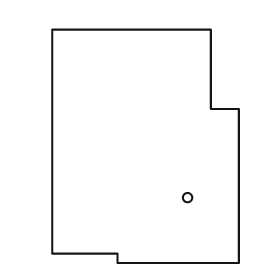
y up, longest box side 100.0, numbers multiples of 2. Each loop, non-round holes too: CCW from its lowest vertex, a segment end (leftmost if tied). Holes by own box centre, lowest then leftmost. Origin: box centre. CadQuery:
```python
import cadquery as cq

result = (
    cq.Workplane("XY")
    .moveTo(-12.0, -50.0)
    .lineTo(40.0, -50.0)
    .lineTo(40.0, 16.0)
    .lineTo(28.0, 16.0)
    .lineTo(28.0, 50.0)
    .lineTo(-40.0, 50.0)
    .lineTo(-40.0, -46.0)
    .lineTo(-12.0, -46.0)
    .close()
    .moveTo(18.0, -22.0)
    .circle(2.0)
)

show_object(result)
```